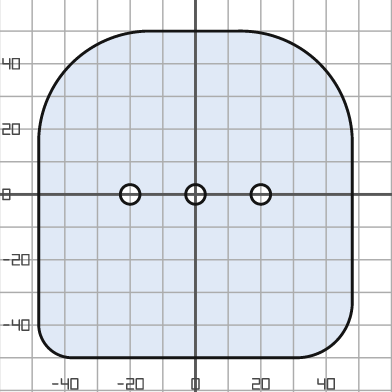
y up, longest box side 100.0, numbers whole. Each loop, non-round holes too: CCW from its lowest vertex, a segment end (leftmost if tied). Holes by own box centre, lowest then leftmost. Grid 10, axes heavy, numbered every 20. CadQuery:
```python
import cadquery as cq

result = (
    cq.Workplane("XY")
    .moveTo(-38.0, -50.0)
    .lineTo(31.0, -50.0)
    .threePointArc((43.0, -45.0), (48.0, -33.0))
    .lineTo(48.0, 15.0)
    .threePointArc((38.0, 40.0), (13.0, 50.0))
    .lineTo(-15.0, 50.0)
    .threePointArc((-38.0, 40.0), (-48.0, 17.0))
    .lineTo(-48.0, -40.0)
    .threePointArc((-45.0, -47.0), (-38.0, -50.0))
    .close()
    .moveTo(-20.0, 0.0)
    .circle(3.0)
    .moveTo(0.0, 0.0)
    .circle(3.0)
    .moveTo(20.0, 0.0)
    .circle(3.0)
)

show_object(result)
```